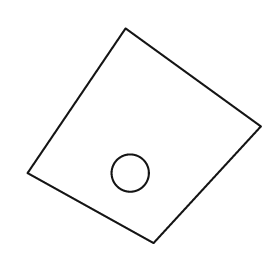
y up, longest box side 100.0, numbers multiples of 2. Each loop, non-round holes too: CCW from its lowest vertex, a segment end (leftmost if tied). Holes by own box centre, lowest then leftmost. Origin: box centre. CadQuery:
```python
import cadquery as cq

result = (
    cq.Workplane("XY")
    .moveTo(4.0, -46.0)
    .lineTo(50.0, 4.0)
    .lineTo(-8.0, 46.0)
    .lineTo(-50.0, -16.0)
    .close()
    .moveTo(-6.0, -16.0)
    .circle(8.0)
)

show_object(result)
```